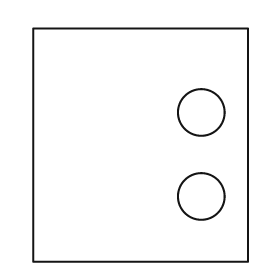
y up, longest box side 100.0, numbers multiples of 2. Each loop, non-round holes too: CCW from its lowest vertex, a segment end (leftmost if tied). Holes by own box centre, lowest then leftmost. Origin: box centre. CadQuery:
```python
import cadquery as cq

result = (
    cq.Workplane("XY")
    .moveTo(-46.0, -50.0)
    .lineTo(46.0, -50.0)
    .lineTo(46.0, 50.0)
    .lineTo(-46.0, 50.0)
    .close()
    .moveTo(26.0, -22.0)
    .circle(10.0)
    .moveTo(26.0, 14.0)
    .circle(10.0)
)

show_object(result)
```